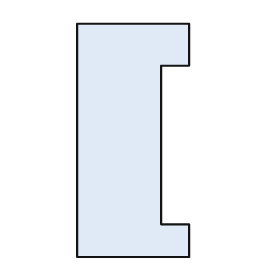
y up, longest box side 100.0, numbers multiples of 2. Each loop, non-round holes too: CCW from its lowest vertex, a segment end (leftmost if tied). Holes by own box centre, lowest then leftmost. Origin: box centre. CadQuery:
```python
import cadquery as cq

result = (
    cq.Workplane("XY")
    .moveTo(-24.0, -50.0)
    .lineTo(24.0, -50.0)
    .lineTo(24.0, -36.0)
    .lineTo(12.0, -36.0)
    .lineTo(12.0, 32.0)
    .lineTo(24.0, 32.0)
    .lineTo(24.0, 50.0)
    .lineTo(-24.0, 50.0)
    .close()
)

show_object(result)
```